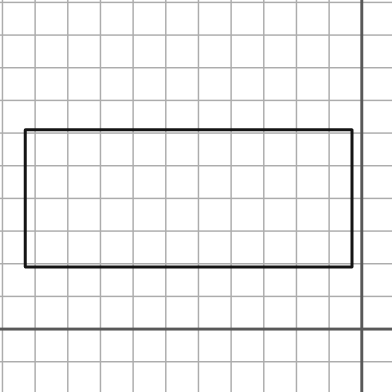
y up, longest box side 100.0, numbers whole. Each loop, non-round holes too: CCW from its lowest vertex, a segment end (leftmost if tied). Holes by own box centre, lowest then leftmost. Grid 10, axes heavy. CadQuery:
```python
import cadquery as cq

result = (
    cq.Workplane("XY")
    .moveTo(-103.0, 19.0)
    .lineTo(-3.0, 19.0)
    .lineTo(-3.0, 61.0)
    .lineTo(-103.0, 61.0)
    .close()
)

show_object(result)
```